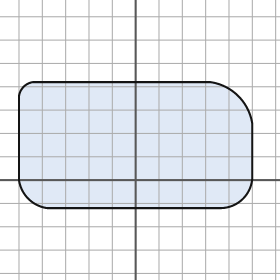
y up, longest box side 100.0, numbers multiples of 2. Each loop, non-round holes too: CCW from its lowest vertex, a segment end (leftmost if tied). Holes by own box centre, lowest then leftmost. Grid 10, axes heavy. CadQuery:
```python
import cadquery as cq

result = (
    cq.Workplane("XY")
    .moveTo(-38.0, -12.0)
    .lineTo(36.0, -12.0)
    .threePointArc((46.0, -8.0), (50.0, 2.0))
    .lineTo(50.0, 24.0)
    .threePointArc((44.0, 36.0), (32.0, 42.0))
    .lineTo(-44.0, 42.0)
    .threePointArc((-48.0, 40.0), (-50.0, 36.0))
    .lineTo(-50.0, 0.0)
    .threePointArc((-46.0, -8.0), (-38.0, -12.0))
    .close()
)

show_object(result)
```